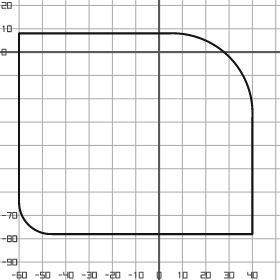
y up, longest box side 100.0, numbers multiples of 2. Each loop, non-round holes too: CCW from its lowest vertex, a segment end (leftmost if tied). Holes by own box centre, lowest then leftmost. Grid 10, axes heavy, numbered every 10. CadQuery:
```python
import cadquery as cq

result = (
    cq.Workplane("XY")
    .moveTo(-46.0, -78.0)
    .lineTo(40.0, -78.0)
    .lineTo(40.0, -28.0)
    .threePointArc((30.0, -2.0), (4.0, 8.0))
    .lineTo(-60.0, 8.0)
    .lineTo(-60.0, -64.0)
    .threePointArc((-56.0, -74.0), (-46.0, -78.0))
    .close()
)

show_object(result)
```